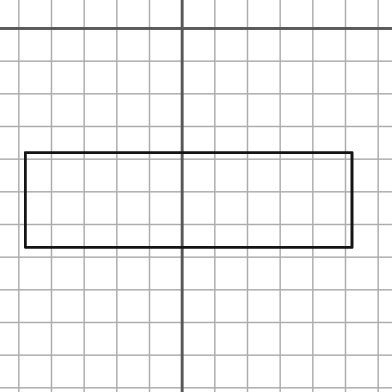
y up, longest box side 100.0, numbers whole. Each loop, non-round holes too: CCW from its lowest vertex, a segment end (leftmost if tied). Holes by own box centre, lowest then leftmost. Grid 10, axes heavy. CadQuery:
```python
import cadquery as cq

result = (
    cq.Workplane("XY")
    .moveTo(-48.0, -67.0)
    .lineTo(52.0, -67.0)
    .lineTo(52.0, -38.0)
    .lineTo(-48.0, -38.0)
    .close()
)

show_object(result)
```